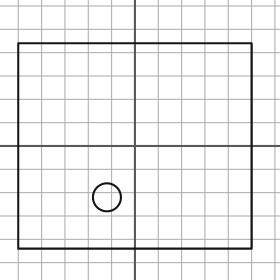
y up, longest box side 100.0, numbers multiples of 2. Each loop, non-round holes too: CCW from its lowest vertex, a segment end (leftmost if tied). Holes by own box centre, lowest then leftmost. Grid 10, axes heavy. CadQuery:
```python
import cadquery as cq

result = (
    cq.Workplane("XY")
    .moveTo(-50.0, -44.0)
    .lineTo(50.0, -44.0)
    .lineTo(50.0, 44.0)
    .lineTo(-50.0, 44.0)
    .close()
    .moveTo(-12.0, -22.0)
    .circle(6.0)
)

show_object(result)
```